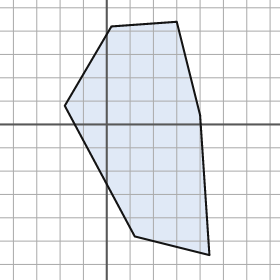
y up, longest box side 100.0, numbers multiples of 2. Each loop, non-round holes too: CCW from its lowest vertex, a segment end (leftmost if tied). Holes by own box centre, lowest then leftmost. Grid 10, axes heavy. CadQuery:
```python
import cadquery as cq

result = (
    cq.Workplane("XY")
    .moveTo(44.0, -56.0)
    .lineTo(40.0, 4.0)
    .lineTo(30.0, 44.0)
    .lineTo(2.0, 42.0)
    .lineTo(-18.0, 8.0)
    .lineTo(12.0, -48.0)
    .close()
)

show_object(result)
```